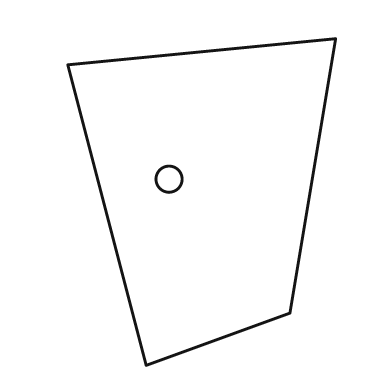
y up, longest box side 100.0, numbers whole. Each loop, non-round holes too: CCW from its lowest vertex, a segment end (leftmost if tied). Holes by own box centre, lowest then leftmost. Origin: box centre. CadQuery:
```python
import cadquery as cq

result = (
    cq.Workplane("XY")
    .moveTo(-17.0, -50.0)
    .lineTo(27.0, -34.0)
    .lineTo(41.0, 50.0)
    .lineTo(-41.0, 42.0)
    .close()
    .moveTo(-10.0, 7.0)
    .circle(4.0)
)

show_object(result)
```